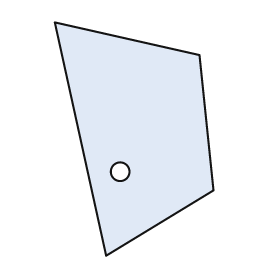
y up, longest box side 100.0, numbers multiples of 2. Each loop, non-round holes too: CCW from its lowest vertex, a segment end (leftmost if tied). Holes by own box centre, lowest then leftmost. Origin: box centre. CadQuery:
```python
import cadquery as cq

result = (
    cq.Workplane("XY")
    .moveTo(-12.0, -50.0)
    .lineTo(34.0, -22.0)
    .lineTo(28.0, 36.0)
    .lineTo(-34.0, 50.0)
    .close()
    .moveTo(-6.0, -14.0)
    .circle(4.0)
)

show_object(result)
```